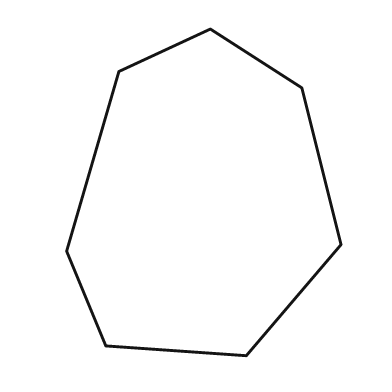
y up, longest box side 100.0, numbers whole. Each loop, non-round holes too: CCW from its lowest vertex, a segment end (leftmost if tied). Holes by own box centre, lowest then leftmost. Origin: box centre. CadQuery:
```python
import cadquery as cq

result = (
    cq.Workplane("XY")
    .moveTo(13.0, -50.0)
    .lineTo(42.0, -16.0)
    .lineTo(30.0, 32.0)
    .lineTo(2.0, 50.0)
    .lineTo(-26.0, 37.0)
    .lineTo(-42.0, -18.0)
    .lineTo(-30.0, -47.0)
    .close()
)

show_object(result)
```